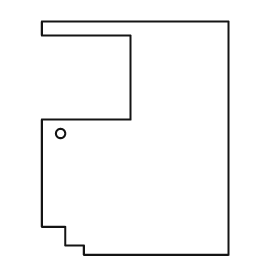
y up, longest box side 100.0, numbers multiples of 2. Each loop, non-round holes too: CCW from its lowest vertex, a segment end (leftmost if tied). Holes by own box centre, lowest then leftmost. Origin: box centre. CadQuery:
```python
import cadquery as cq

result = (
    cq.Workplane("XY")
    .moveTo(-22.0, -50.0)
    .lineTo(40.0, -50.0)
    .lineTo(40.0, 50.0)
    .lineTo(-40.0, 50.0)
    .lineTo(-40.0, 44.0)
    .lineTo(-2.0, 44.0)
    .lineTo(-2.0, 8.0)
    .lineTo(-40.0, 8.0)
    .lineTo(-40.0, -38.0)
    .lineTo(-30.0, -38.0)
    .lineTo(-30.0, -46.0)
    .lineTo(-22.0, -46.0)
    .close()
    .moveTo(-32.0, 2.0)
    .circle(2.0)
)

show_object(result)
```